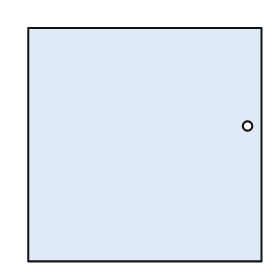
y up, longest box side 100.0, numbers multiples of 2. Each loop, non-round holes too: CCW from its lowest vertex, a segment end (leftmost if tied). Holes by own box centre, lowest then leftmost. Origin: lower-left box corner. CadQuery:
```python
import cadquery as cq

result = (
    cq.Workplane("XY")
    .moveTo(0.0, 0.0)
    .lineTo(100.0, 0.0)
    .lineTo(100.0, 100.0)
    .lineTo(0.0, 100.0)
    .close()
    .moveTo(94.0, 58.0)
    .circle(2.0)
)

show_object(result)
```